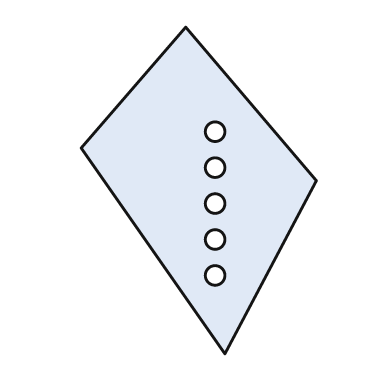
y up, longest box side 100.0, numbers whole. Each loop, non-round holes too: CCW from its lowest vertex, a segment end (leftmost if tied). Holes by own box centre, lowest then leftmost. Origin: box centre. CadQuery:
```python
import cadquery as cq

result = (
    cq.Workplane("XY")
    .moveTo(8.0, -50.0)
    .lineTo(36.0, 3.0)
    .lineTo(-4.0, 50.0)
    .lineTo(-36.0, 13.0)
    .close()
    .moveTo(5.0, -26.0)
    .circle(3.0)
    .moveTo(5.0, -15.0)
    .circle(3.0)
    .moveTo(5.0, -4.0)
    .circle(3.0)
    .moveTo(5.0, 7.0)
    .circle(3.0)
    .moveTo(5.0, 18.0)
    .circle(3.0)
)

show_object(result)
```